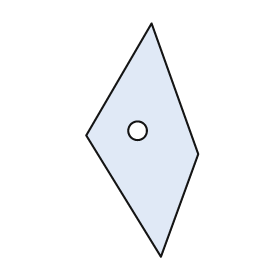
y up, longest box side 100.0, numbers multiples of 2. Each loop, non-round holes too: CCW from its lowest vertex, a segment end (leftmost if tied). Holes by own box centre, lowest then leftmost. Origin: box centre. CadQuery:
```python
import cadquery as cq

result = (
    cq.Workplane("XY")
    .moveTo(8.0, -50.0)
    .lineTo(24.0, -6.0)
    .lineTo(4.0, 50.0)
    .lineTo(-24.0, 2.0)
    .close()
    .moveTo(-2.0, 4.0)
    .circle(4.0)
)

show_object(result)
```